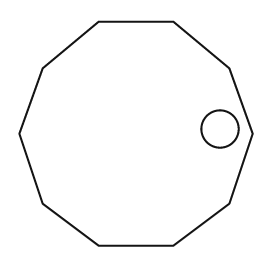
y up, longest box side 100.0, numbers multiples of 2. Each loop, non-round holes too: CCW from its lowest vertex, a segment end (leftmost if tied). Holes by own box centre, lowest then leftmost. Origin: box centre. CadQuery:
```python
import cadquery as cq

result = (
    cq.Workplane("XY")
    .moveTo(-16.0, -48.0)
    .lineTo(16.0, -48.0)
    .lineTo(40.0, -30.0)
    .lineTo(50.0, 0.0)
    .lineTo(40.0, 28.0)
    .lineTo(16.0, 48.0)
    .lineTo(-16.0, 48.0)
    .lineTo(-40.0, 28.0)
    .lineTo(-50.0, 0.0)
    .lineTo(-40.0, -30.0)
    .close()
    .moveTo(36.0, 2.0)
    .circle(8.0)
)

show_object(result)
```